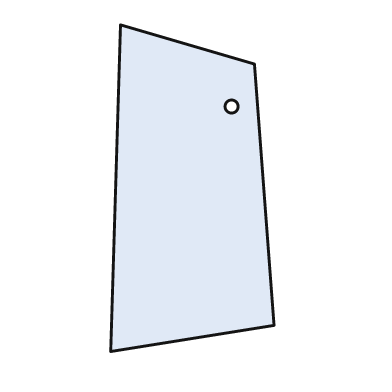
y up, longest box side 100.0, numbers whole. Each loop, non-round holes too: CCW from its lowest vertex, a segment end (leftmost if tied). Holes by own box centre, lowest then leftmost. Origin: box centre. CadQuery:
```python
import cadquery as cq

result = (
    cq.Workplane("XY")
    .moveTo(-25.0, -50.0)
    .lineTo(25.0, -42.0)
    .lineTo(19.0, 38.0)
    .lineTo(-22.0, 50.0)
    .close()
    .moveTo(12.0, 25.0)
    .circle(2.0)
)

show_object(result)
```